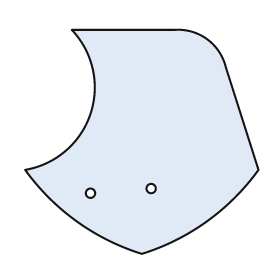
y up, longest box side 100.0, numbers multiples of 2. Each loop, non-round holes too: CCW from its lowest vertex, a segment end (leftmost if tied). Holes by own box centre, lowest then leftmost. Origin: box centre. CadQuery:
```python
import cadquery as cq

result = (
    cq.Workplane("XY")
    .moveTo(0.0, -48.0)
    .threePointArc((28.0, -34.0), (50.0, -12.0))
    .lineTo(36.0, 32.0)
    .threePointArc((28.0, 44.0), (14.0, 48.0))
    .lineTo(-30.0, 48.0)
    .threePointArc((-22.0, 12.0), (-50.0, -12.0))
    .threePointArc((-28.0, -34.0), (0.0, -48.0))
    .close()
    .moveTo(-22.0, -22.0)
    .circle(2.0)
    .moveTo(4.0, -20.0)
    .circle(2.0)
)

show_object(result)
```